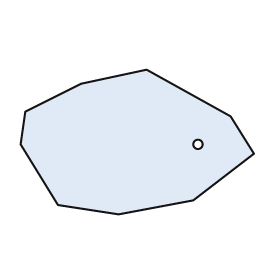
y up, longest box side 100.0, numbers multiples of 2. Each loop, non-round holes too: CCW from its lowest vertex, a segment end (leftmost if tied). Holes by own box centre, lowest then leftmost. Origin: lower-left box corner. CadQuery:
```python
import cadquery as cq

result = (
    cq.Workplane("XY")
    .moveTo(42.0, 0.0)
    .lineTo(74.0, 6.0)
    .lineTo(100.0, 26.0)
    .lineTo(90.0, 42.0)
    .lineTo(54.0, 62.0)
    .lineTo(26.0, 56.0)
    .lineTo(2.0, 44.0)
    .lineTo(0.0, 30.0)
    .lineTo(16.0, 4.0)
    .close()
    .moveTo(76.0, 30.0)
    .circle(2.0)
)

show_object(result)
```